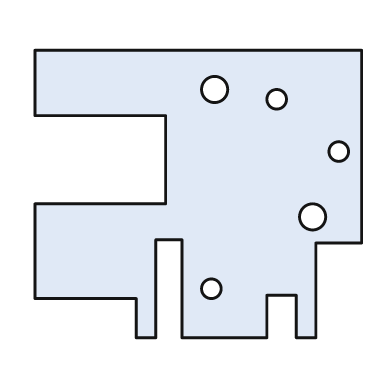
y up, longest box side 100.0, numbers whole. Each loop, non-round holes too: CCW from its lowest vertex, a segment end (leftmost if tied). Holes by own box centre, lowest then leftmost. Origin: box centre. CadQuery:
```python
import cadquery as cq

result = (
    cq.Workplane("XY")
    .moveTo(-19.0, -44.0)
    .lineTo(-13.0, -44.0)
    .lineTo(-13.0, -14.0)
    .lineTo(-5.0, -14.0)
    .lineTo(-5.0, -44.0)
    .lineTo(21.0, -44.0)
    .lineTo(21.0, -31.0)
    .lineTo(30.0, -31.0)
    .lineTo(30.0, -44.0)
    .lineTo(36.0, -44.0)
    .lineTo(36.0, -15.0)
    .lineTo(50.0, -15.0)
    .lineTo(50.0, 44.0)
    .lineTo(-50.0, 44.0)
    .lineTo(-50.0, 24.0)
    .lineTo(-10.0, 24.0)
    .lineTo(-10.0, -3.0)
    .lineTo(-50.0, -3.0)
    .lineTo(-50.0, -32.0)
    .lineTo(-19.0, -32.0)
    .close()
    .moveTo(4.0, -29.0)
    .circle(3.0)
    .moveTo(35.0, -7.0)
    .circle(4.0)
    .moveTo(43.0, 13.0)
    .circle(3.0)
    .moveTo(24.0, 29.0)
    .circle(3.0)
    .moveTo(5.0, 32.0)
    .circle(4.0)
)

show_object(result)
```